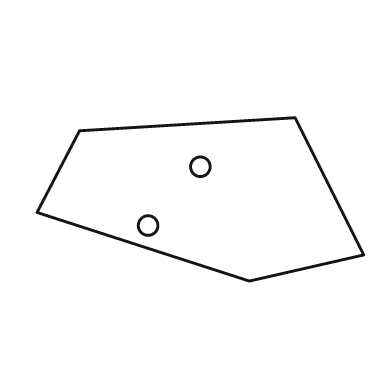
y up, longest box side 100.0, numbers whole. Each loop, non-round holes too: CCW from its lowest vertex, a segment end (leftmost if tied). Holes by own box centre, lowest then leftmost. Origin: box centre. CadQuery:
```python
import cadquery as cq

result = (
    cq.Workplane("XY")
    .moveTo(15.0, -25.0)
    .lineTo(50.0, -17.0)
    .lineTo(29.0, 25.0)
    .lineTo(-37.0, 21.0)
    .lineTo(-50.0, -4.0)
    .close()
    .moveTo(-16.0, -8.0)
    .circle(3.0)
    .moveTo(0.0, 10.0)
    .circle(3.0)
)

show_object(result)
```